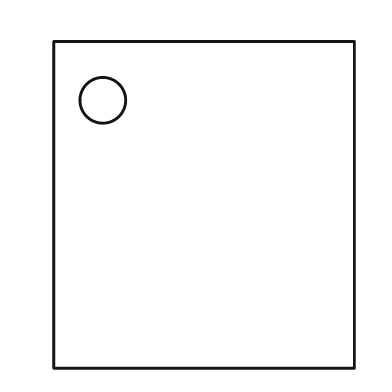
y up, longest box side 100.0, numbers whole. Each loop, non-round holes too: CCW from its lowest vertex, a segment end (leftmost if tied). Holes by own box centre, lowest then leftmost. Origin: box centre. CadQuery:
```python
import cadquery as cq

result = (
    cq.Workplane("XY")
    .moveTo(-46.0, -50.0)
    .lineTo(46.0, -50.0)
    .lineTo(46.0, 50.0)
    .lineTo(-46.0, 50.0)
    .close()
    .moveTo(-31.0, 32.0)
    .circle(7.0)
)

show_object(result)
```